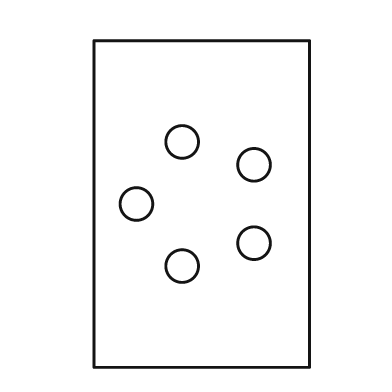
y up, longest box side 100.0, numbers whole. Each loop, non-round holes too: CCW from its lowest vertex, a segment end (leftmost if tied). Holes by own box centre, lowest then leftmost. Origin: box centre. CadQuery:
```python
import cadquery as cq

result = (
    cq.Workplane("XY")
    .moveTo(-33.0, -50.0)
    .lineTo(33.0, -50.0)
    .lineTo(33.0, 50.0)
    .lineTo(-33.0, 50.0)
    .close()
    .moveTo(-6.0, -19.0)
    .circle(5.0)
    .moveTo(16.0, -12.0)
    .circle(5.0)
    .moveTo(-20.0, 0.0)
    .circle(5.0)
    .moveTo(16.0, 12.0)
    .circle(5.0)
    .moveTo(-6.0, 19.0)
    .circle(5.0)
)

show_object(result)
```